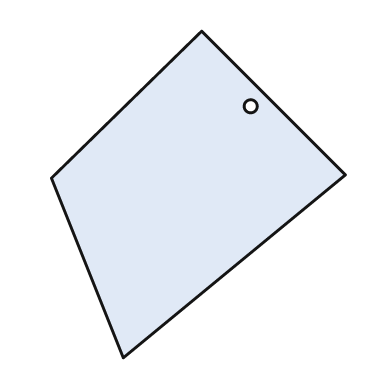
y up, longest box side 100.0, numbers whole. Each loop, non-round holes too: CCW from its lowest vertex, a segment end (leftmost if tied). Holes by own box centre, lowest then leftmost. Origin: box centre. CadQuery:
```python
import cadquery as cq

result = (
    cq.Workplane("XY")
    .moveTo(-23.0, -50.0)
    .lineTo(45.0, 6.0)
    .lineTo(1.0, 50.0)
    .lineTo(-45.0, 5.0)
    .close()
    .moveTo(16.0, 27.0)
    .circle(2.0)
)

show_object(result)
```